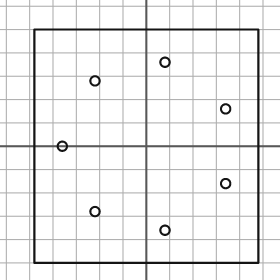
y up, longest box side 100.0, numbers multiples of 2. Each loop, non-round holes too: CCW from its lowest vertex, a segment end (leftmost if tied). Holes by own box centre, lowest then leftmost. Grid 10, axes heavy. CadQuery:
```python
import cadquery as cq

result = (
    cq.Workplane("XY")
    .moveTo(-48.0, -50.0)
    .lineTo(48.0, -50.0)
    .lineTo(48.0, 50.0)
    .lineTo(-48.0, 50.0)
    .close()
    .moveTo(8.0, -36.0)
    .circle(2.0)
    .moveTo(-22.0, -28.0)
    .circle(2.0)
    .moveTo(34.0, -16.0)
    .circle(2.0)
    .moveTo(-36.0, 0.0)
    .circle(2.0)
    .moveTo(34.0, 16.0)
    .circle(2.0)
    .moveTo(-22.0, 28.0)
    .circle(2.0)
    .moveTo(8.0, 36.0)
    .circle(2.0)
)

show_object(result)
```